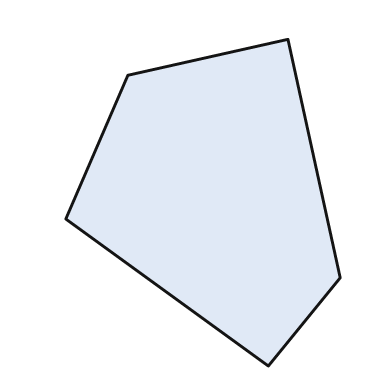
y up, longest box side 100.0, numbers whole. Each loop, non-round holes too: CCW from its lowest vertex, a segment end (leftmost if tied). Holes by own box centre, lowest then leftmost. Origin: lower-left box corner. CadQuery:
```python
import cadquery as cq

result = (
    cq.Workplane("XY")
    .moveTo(62.0, 0.0)
    .lineTo(84.0, 27.0)
    .lineTo(68.0, 100.0)
    .lineTo(19.0, 89.0)
    .lineTo(0.0, 45.0)
    .close()
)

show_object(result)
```